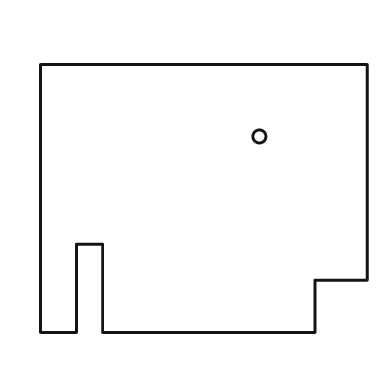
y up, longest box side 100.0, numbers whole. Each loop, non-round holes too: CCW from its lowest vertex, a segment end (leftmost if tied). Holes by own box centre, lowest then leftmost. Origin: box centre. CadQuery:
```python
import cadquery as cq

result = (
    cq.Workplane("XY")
    .moveTo(-50.0, -41.0)
    .lineTo(-39.0, -41.0)
    .lineTo(-39.0, -14.0)
    .lineTo(-31.0, -14.0)
    .lineTo(-31.0, -41.0)
    .lineTo(34.0, -41.0)
    .lineTo(34.0, -25.0)
    .lineTo(50.0, -25.0)
    .lineTo(50.0, 41.0)
    .lineTo(-50.0, 41.0)
    .close()
    .moveTo(17.0, 19.0)
    .circle(2.0)
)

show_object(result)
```